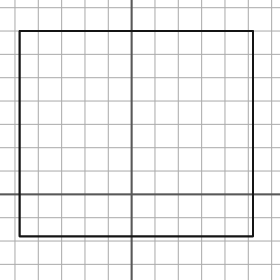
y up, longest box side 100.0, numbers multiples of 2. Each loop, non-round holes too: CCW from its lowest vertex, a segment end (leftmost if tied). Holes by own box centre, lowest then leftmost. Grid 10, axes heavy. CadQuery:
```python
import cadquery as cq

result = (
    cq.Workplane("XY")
    .moveTo(-48.0, -18.0)
    .lineTo(52.0, -18.0)
    .lineTo(52.0, 70.0)
    .lineTo(-48.0, 70.0)
    .close()
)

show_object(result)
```